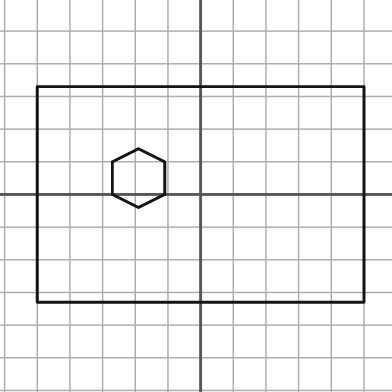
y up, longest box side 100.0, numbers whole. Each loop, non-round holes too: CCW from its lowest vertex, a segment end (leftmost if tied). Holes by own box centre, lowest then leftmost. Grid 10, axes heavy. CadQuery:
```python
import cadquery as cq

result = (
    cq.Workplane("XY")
    .moveTo(-50.0, -33.0)
    .lineTo(50.0, -33.0)
    .lineTo(50.0, 33.0)
    .lineTo(-50.0, 33.0)
    .close()
    .moveTo(-19.0, -4.0)
    .lineTo(-11.0, 0.0)
    .lineTo(-11.0, 10.0)
    .lineTo(-19.0, 14.0)
    .lineTo(-27.0, 10.0)
    .lineTo(-27.0, 0.0)
    .close()
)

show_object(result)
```